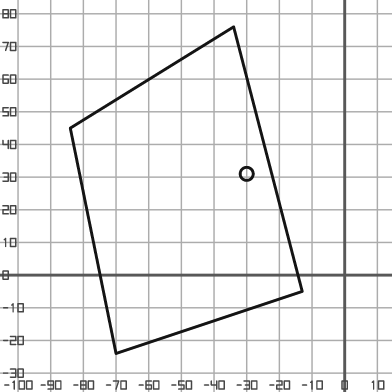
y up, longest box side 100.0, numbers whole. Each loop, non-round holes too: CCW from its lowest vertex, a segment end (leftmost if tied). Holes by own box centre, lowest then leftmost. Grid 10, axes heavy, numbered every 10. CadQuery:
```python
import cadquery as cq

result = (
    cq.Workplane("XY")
    .moveTo(-70.0, -24.0)
    .lineTo(-13.0, -5.0)
    .lineTo(-34.0, 76.0)
    .lineTo(-84.0, 45.0)
    .close()
    .moveTo(-30.0, 31.0)
    .circle(2.0)
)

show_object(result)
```